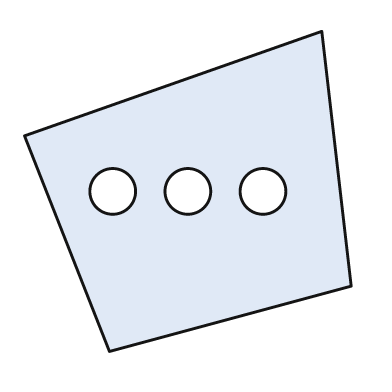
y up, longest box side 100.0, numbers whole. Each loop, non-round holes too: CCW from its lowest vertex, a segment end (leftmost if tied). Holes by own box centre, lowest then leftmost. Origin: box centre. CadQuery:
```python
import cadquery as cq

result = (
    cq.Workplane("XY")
    .moveTo(-24.0, -49.0)
    .lineTo(50.0, -29.0)
    .lineTo(41.0, 49.0)
    .lineTo(-50.0, 17.0)
    .close()
    .moveTo(-23.0, 0.0)
    .circle(7.0)
    .moveTo(0.0, 0.0)
    .circle(7.0)
    .moveTo(23.0, 0.0)
    .circle(7.0)
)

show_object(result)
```